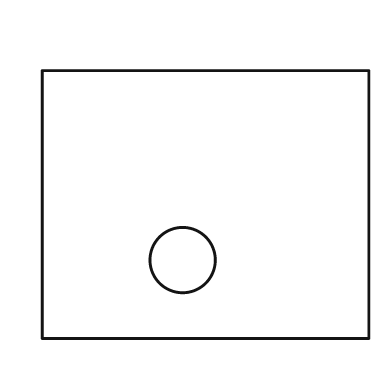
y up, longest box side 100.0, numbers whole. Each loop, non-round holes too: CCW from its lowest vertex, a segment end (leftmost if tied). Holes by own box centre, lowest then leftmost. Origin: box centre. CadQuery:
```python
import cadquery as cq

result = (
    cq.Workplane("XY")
    .moveTo(-50.0, -41.0)
    .lineTo(50.0, -41.0)
    .lineTo(50.0, 41.0)
    .lineTo(-50.0, 41.0)
    .close()
    .moveTo(-7.0, -17.0)
    .circle(10.0)
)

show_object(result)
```